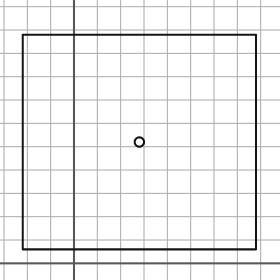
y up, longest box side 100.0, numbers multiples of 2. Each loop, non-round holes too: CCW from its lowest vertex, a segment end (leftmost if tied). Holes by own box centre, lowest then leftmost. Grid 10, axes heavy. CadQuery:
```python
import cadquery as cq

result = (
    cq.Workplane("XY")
    .moveTo(-22.0, 6.0)
    .lineTo(78.0, 6.0)
    .lineTo(78.0, 98.0)
    .lineTo(-22.0, 98.0)
    .close()
    .moveTo(28.0, 52.0)
    .circle(2.0)
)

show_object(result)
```